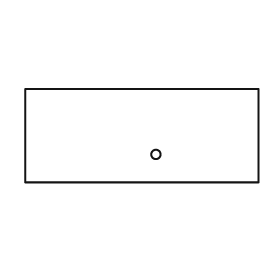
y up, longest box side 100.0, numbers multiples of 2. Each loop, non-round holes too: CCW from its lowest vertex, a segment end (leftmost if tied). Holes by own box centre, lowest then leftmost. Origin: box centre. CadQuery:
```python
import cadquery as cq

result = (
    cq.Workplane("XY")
    .moveTo(-50.0, -20.0)
    .lineTo(50.0, -20.0)
    .lineTo(50.0, 20.0)
    .lineTo(-50.0, 20.0)
    .close()
    .moveTo(6.0, -8.0)
    .circle(2.0)
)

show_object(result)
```